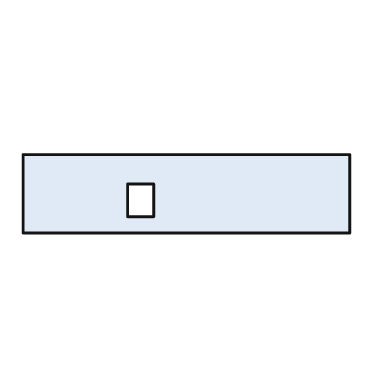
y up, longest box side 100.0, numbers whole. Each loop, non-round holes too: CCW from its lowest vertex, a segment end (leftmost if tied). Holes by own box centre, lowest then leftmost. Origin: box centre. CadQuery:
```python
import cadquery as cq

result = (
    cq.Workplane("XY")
    .moveTo(-50.0, -12.0)
    .lineTo(50.0, -12.0)
    .lineTo(50.0, 12.0)
    .lineTo(-50.0, 12.0)
    .close()
    .moveTo(-18.0, -7.0)
    .lineTo(-10.0, -7.0)
    .lineTo(-10.0, 3.0)
    .lineTo(-18.0, 3.0)
    .close()
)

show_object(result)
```